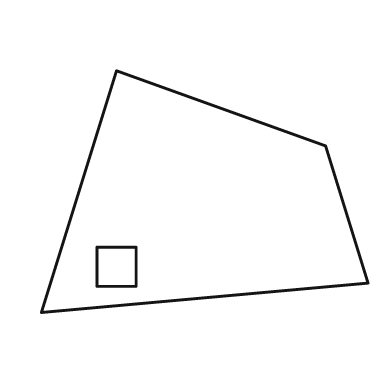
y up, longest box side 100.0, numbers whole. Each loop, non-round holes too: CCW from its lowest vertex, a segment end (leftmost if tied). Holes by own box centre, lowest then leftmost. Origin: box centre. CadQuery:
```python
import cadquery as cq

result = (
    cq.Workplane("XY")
    .moveTo(-50.0, -37.0)
    .lineTo(50.0, -28.0)
    .lineTo(37.0, 14.0)
    .lineTo(-27.0, 37.0)
    .close()
    .moveTo(-33.0, -29.0)
    .lineTo(-21.0, -29.0)
    .lineTo(-21.0, -17.0)
    .lineTo(-33.0, -17.0)
    .close()
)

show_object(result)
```